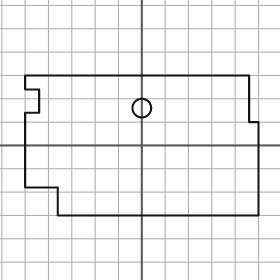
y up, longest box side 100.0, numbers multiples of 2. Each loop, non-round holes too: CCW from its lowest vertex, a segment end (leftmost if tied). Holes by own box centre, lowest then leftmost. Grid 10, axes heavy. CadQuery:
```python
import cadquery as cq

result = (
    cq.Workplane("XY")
    .moveTo(-36.0, -30.0)
    .lineTo(50.0, -30.0)
    .lineTo(50.0, 10.0)
    .lineTo(46.0, 10.0)
    .lineTo(46.0, 30.0)
    .lineTo(-50.0, 30.0)
    .lineTo(-50.0, 24.0)
    .lineTo(-44.0, 24.0)
    .lineTo(-44.0, 14.0)
    .lineTo(-50.0, 14.0)
    .lineTo(-50.0, -18.0)
    .lineTo(-36.0, -18.0)
    .close()
    .moveTo(0.0, 16.0)
    .circle(4.0)
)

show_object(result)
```